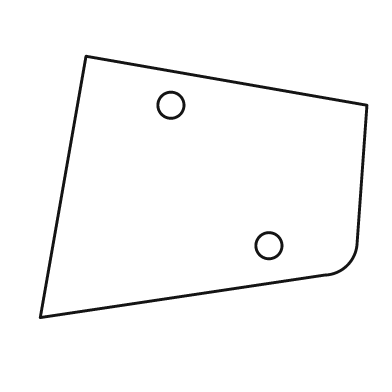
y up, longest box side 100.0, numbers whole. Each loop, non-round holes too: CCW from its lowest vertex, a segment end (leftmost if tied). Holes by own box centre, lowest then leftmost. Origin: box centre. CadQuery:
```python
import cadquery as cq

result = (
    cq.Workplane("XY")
    .moveTo(-50.0, -40.0)
    .lineTo(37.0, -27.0)
    .threePointArc((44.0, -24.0), (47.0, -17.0))
    .lineTo(50.0, 25.0)
    .lineTo(-36.0, 40.0)
    .close()
    .moveTo(20.0, -18.0)
    .circle(4.0)
    .moveTo(-10.0, 25.0)
    .circle(4.0)
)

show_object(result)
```